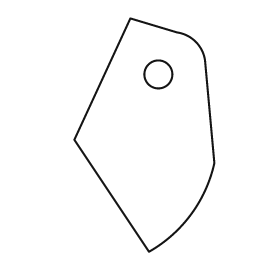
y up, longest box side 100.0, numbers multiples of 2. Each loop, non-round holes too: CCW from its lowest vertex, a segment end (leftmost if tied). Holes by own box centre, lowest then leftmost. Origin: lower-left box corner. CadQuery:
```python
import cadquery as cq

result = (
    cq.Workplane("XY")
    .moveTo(32.0, 0.0)
    .threePointArc((50.0, 16.0), (60.0, 38.0))
    .lineTo(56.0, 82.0)
    .threePointArc((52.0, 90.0), (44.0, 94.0))
    .lineTo(24.0, 100.0)
    .lineTo(0.0, 48.0)
    .close()
    .moveTo(36.0, 76.0)
    .circle(6.0)
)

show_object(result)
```